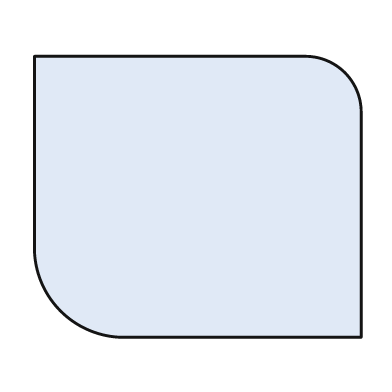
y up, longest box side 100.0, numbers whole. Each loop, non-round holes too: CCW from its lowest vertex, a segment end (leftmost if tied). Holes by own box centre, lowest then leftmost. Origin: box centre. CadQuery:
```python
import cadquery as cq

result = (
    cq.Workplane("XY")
    .moveTo(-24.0, -43.0)
    .lineTo(50.0, -43.0)
    .lineTo(50.0, 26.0)
    .threePointArc((45.0, 38.0), (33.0, 43.0))
    .lineTo(-50.0, 43.0)
    .lineTo(-50.0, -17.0)
    .threePointArc((-42.0, -35.0), (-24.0, -43.0))
    .close()
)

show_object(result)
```